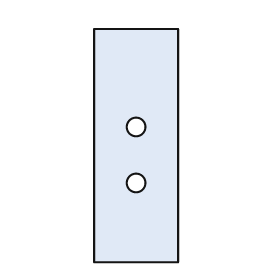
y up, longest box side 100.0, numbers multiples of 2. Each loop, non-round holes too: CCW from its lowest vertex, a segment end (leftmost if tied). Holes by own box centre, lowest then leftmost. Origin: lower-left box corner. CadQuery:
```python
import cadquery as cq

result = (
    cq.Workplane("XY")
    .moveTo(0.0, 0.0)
    .lineTo(36.0, 0.0)
    .lineTo(36.0, 100.0)
    .lineTo(0.0, 100.0)
    .close()
    .moveTo(18.0, 34.0)
    .circle(4.0)
    .moveTo(18.0, 58.0)
    .circle(4.0)
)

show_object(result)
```